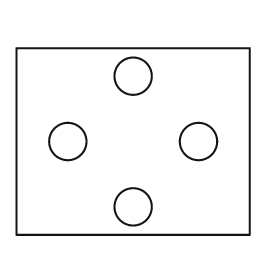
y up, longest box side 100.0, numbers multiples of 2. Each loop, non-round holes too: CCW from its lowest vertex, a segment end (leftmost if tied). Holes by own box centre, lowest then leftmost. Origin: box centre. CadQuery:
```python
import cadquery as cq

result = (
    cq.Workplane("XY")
    .moveTo(-50.0, -40.0)
    .lineTo(50.0, -40.0)
    .lineTo(50.0, 40.0)
    .lineTo(-50.0, 40.0)
    .close()
    .moveTo(0.0, -28.0)
    .circle(8.0)
    .moveTo(-28.0, 0.0)
    .circle(8.0)
    .moveTo(28.0, 0.0)
    .circle(8.0)
    .moveTo(0.0, 28.0)
    .circle(8.0)
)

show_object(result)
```